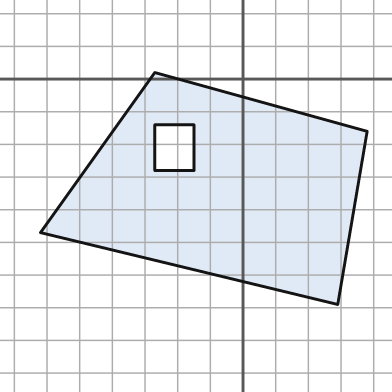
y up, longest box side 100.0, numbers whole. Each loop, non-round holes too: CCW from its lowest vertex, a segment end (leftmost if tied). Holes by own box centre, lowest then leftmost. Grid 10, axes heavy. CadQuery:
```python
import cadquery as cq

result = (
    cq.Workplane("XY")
    .moveTo(29.0, -69.0)
    .lineTo(38.0, -16.0)
    .lineTo(-27.0, 2.0)
    .lineTo(-62.0, -47.0)
    .close()
    .moveTo(-27.0, -28.0)
    .lineTo(-15.0, -28.0)
    .lineTo(-15.0, -14.0)
    .lineTo(-27.0, -14.0)
    .close()
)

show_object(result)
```